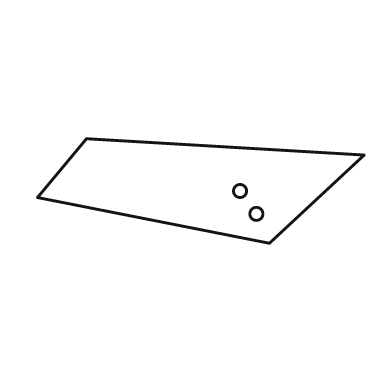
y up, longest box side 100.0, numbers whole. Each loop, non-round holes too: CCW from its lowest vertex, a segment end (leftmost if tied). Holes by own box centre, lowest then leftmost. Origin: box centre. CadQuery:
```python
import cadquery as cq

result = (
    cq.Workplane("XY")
    .moveTo(21.0, -16.0)
    .lineTo(50.0, 11.0)
    .lineTo(-35.0, 16.0)
    .lineTo(-50.0, -2.0)
    .close()
    .moveTo(17.0, -7.0)
    .circle(2.0)
    .moveTo(12.0, 0.0)
    .circle(2.0)
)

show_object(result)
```